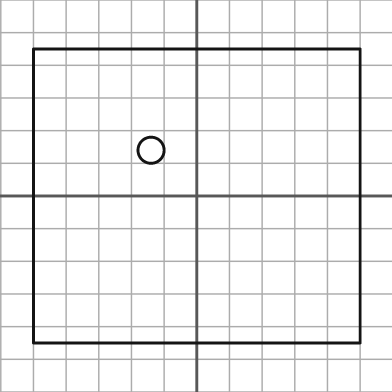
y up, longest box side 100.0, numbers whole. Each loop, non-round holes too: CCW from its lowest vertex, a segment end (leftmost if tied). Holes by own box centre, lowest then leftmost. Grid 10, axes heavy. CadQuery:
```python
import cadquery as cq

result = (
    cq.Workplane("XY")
    .moveTo(-50.0, -45.0)
    .lineTo(50.0, -45.0)
    .lineTo(50.0, 45.0)
    .lineTo(-50.0, 45.0)
    .close()
    .moveTo(-14.0, 14.0)
    .circle(4.0)
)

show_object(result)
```